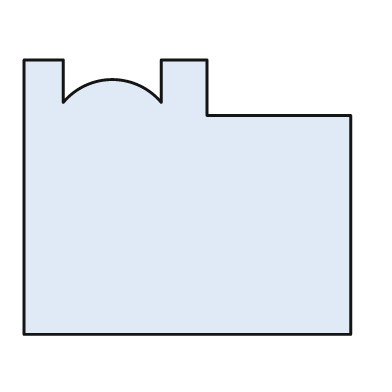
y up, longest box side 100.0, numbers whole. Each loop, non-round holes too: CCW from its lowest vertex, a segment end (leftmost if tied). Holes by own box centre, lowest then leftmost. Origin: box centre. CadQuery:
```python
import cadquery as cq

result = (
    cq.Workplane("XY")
    .moveTo(-50.0, -42.0)
    .lineTo(50.0, -42.0)
    .lineTo(50.0, 25.0)
    .lineTo(6.0, 25.0)
    .lineTo(6.0, 42.0)
    .lineTo(-8.0, 42.0)
    .lineTo(-8.0, 29.0)
    .threePointArc((-23.0, 36.0), (-38.0, 29.0))
    .lineTo(-38.0, 42.0)
    .lineTo(-50.0, 42.0)
    .close()
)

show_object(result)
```